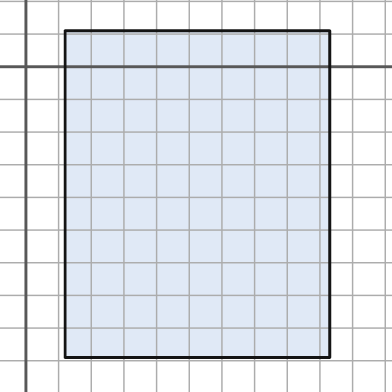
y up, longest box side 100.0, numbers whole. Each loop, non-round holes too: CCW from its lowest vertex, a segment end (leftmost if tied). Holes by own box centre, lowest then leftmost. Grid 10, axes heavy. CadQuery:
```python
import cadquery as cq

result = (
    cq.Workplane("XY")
    .moveTo(12.0, -89.0)
    .lineTo(93.0, -89.0)
    .lineTo(93.0, 11.0)
    .lineTo(12.0, 11.0)
    .close()
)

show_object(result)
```